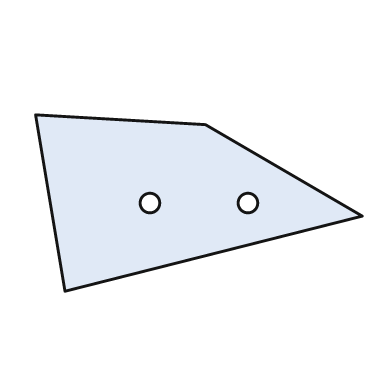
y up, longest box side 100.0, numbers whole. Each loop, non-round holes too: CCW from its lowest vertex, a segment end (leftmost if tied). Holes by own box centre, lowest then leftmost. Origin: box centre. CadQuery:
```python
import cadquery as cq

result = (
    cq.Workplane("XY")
    .moveTo(-41.0, -27.0)
    .lineTo(50.0, -4.0)
    .lineTo(2.0, 24.0)
    .lineTo(-50.0, 27.0)
    .close()
    .moveTo(-15.0, 0.0)
    .circle(3.0)
    .moveTo(15.0, 0.0)
    .circle(3.0)
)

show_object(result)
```